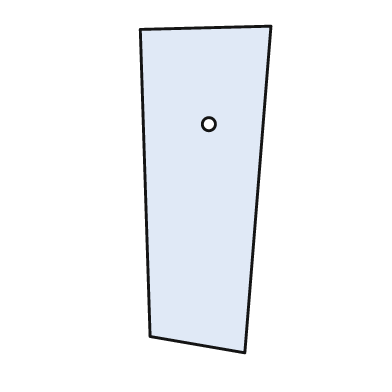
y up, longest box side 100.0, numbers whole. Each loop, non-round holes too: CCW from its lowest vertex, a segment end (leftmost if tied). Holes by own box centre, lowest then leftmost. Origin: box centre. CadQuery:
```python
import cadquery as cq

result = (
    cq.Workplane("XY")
    .moveTo(12.0, -50.0)
    .lineTo(20.0, 50.0)
    .lineTo(-20.0, 49.0)
    .lineTo(-17.0, -45.0)
    .close()
    .moveTo(1.0, 20.0)
    .circle(2.0)
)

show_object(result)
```